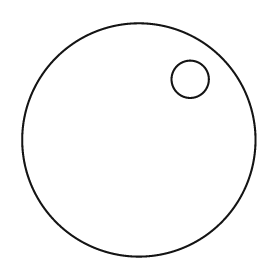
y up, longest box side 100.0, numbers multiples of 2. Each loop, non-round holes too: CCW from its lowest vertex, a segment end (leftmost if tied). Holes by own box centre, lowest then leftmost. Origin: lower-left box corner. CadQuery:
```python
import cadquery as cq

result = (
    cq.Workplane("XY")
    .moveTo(50.0, 50.0)
    .circle(50.0)
    .moveTo(72.0, 76.0)
    .circle(8.0)
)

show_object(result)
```